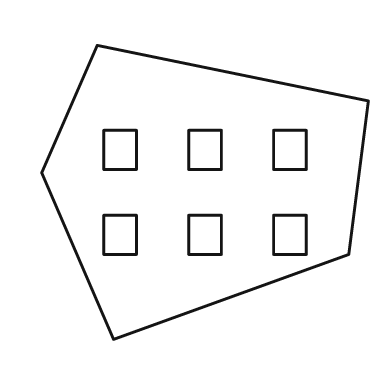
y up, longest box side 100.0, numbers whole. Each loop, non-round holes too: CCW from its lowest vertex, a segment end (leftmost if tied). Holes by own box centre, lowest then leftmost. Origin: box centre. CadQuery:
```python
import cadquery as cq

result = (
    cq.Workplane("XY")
    .moveTo(-28.0, -45.0)
    .lineTo(44.0, -19.0)
    .lineTo(50.0, 28.0)
    .lineTo(-33.0, 45.0)
    .lineTo(-50.0, 6.0)
    .close()
    .moveTo(-31.0, -19.0)
    .lineTo(-21.0, -19.0)
    .lineTo(-21.0, -7.0)
    .lineTo(-31.0, -7.0)
    .close()
    .moveTo(-5.0, -19.0)
    .lineTo(5.0, -19.0)
    .lineTo(5.0, -7.0)
    .lineTo(-5.0, -7.0)
    .close()
    .moveTo(21.0, -19.0)
    .lineTo(31.0, -19.0)
    .lineTo(31.0, -7.0)
    .lineTo(21.0, -7.0)
    .close()
    .moveTo(-31.0, 7.0)
    .lineTo(-21.0, 7.0)
    .lineTo(-21.0, 19.0)
    .lineTo(-31.0, 19.0)
    .close()
    .moveTo(-5.0, 7.0)
    .lineTo(5.0, 7.0)
    .lineTo(5.0, 19.0)
    .lineTo(-5.0, 19.0)
    .close()
    .moveTo(21.0, 7.0)
    .lineTo(31.0, 7.0)
    .lineTo(31.0, 19.0)
    .lineTo(21.0, 19.0)
    .close()
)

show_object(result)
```